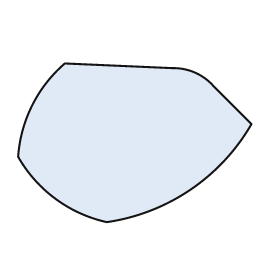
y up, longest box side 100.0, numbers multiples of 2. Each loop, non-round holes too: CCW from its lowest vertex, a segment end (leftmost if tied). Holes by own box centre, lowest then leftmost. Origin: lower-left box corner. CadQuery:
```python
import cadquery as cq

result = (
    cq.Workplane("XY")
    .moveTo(38.0, 0.0)
    .threePointArc((74.0, 14.0), (100.0, 42.0))
    .lineTo(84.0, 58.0)
    .threePointArc((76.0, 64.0), (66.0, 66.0))
    .lineTo(20.0, 68.0)
    .threePointArc((6.0, 50.0), (0.0, 28.0))
    .threePointArc((16.0, 10.0), (38.0, 0.0))
    .close()
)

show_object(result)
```